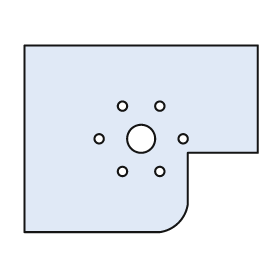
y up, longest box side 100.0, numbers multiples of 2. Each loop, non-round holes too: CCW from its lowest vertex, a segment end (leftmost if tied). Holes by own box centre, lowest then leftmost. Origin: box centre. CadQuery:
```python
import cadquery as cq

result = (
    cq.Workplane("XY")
    .moveTo(-50.0, -40.0)
    .lineTo(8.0, -40.0)
    .threePointArc((16.0, -36.0), (20.0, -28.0))
    .lineTo(20.0, -6.0)
    .lineTo(50.0, -6.0)
    .lineTo(50.0, 40.0)
    .lineTo(-50.0, 40.0)
    .close()
    .moveTo(-8.0, -14.0)
    .circle(2.0)
    .moveTo(8.0, -14.0)
    .circle(2.0)
    .moveTo(-18.0, 0.0)
    .circle(2.0)
    .moveTo(0.0, 0.0)
    .circle(6.0)
    .moveTo(18.0, 0.0)
    .circle(2.0)
    .moveTo(-8.0, 14.0)
    .circle(2.0)
    .moveTo(8.0, 14.0)
    .circle(2.0)
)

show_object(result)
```